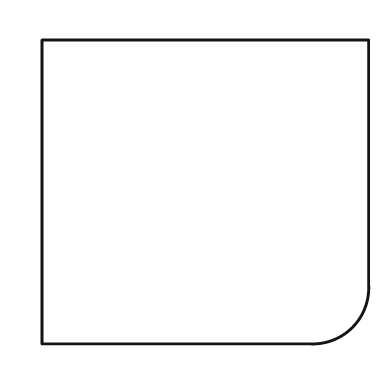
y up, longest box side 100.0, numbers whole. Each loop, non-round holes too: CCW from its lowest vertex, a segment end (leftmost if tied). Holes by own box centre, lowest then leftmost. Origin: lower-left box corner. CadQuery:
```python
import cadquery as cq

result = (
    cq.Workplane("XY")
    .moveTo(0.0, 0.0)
    .lineTo(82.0, 0.0)
    .threePointArc((95.0, 5.0), (100.0, 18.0))
    .lineTo(100.0, 93.0)
    .lineTo(0.0, 93.0)
    .close()
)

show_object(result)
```